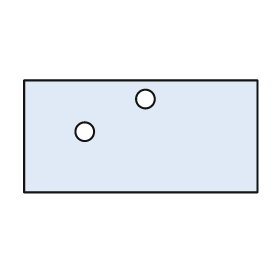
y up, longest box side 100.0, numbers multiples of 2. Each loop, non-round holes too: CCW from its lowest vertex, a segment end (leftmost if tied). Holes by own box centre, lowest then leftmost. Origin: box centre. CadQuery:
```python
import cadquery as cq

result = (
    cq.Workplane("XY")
    .moveTo(-50.0, -24.0)
    .lineTo(50.0, -24.0)
    .lineTo(50.0, 24.0)
    .lineTo(-50.0, 24.0)
    .close()
    .moveTo(-24.0, 2.0)
    .circle(4.0)
    .moveTo(2.0, 16.0)
    .circle(4.0)
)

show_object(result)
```